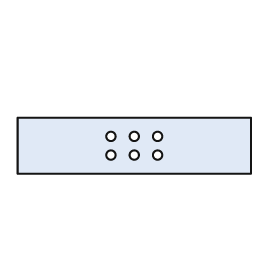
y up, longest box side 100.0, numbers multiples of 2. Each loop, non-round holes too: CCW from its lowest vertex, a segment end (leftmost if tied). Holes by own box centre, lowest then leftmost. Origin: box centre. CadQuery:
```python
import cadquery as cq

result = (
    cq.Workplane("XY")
    .moveTo(-50.0, -12.0)
    .lineTo(50.0, -12.0)
    .lineTo(50.0, 12.0)
    .lineTo(-50.0, 12.0)
    .close()
    .moveTo(-10.0, -4.0)
    .circle(2.0)
    .moveTo(0.0, -4.0)
    .circle(2.0)
    .moveTo(10.0, -4.0)
    .circle(2.0)
    .moveTo(-10.0, 4.0)
    .circle(2.0)
    .moveTo(0.0, 4.0)
    .circle(2.0)
    .moveTo(10.0, 4.0)
    .circle(2.0)
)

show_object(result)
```